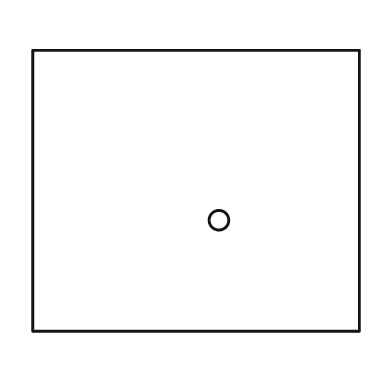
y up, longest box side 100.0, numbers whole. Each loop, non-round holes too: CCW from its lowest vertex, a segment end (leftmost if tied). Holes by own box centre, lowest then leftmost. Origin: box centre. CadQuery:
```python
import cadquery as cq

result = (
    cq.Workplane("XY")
    .moveTo(-50.0, -43.0)
    .lineTo(50.0, -43.0)
    .lineTo(50.0, 43.0)
    .lineTo(-50.0, 43.0)
    .close()
    .moveTo(7.0, -9.0)
    .circle(3.0)
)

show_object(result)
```